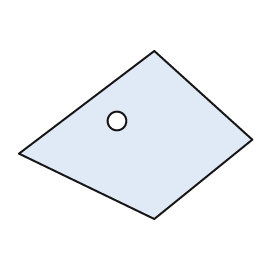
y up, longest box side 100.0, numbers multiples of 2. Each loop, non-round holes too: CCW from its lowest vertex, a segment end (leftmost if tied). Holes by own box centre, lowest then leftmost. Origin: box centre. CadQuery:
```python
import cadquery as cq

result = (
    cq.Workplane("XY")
    .moveTo(8.0, -36.0)
    .lineTo(50.0, -2.0)
    .lineTo(8.0, 36.0)
    .lineTo(-50.0, -8.0)
    .close()
    .moveTo(-8.0, 6.0)
    .circle(4.0)
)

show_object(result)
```